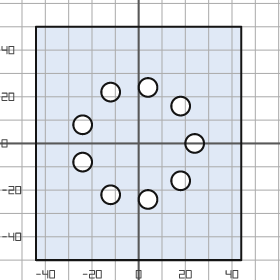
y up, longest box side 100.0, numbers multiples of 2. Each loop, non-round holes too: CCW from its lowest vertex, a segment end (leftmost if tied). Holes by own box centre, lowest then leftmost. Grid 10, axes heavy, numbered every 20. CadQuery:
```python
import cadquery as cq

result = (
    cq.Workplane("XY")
    .moveTo(-44.0, -50.0)
    .lineTo(44.0, -50.0)
    .lineTo(44.0, 50.0)
    .lineTo(-44.0, 50.0)
    .close()
    .moveTo(4.0, -24.0)
    .circle(4.0)
    .moveTo(-12.0, -22.0)
    .circle(4.0)
    .moveTo(18.0, -16.0)
    .circle(4.0)
    .moveTo(-24.0, -8.0)
    .circle(4.0)
    .moveTo(24.0, 0.0)
    .circle(4.0)
    .moveTo(-24.0, 8.0)
    .circle(4.0)
    .moveTo(18.0, 16.0)
    .circle(4.0)
    .moveTo(-12.0, 22.0)
    .circle(4.0)
    .moveTo(4.0, 24.0)
    .circle(4.0)
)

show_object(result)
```